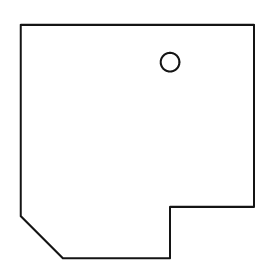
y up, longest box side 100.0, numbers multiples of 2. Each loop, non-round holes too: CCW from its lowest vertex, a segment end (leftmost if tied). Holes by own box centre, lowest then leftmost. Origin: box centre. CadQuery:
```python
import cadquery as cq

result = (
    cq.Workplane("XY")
    .moveTo(-32.0, -50.0)
    .lineTo(14.0, -50.0)
    .lineTo(14.0, -28.0)
    .lineTo(50.0, -28.0)
    .lineTo(50.0, 50.0)
    .lineTo(-50.0, 50.0)
    .lineTo(-50.0, -32.0)
    .close()
    .moveTo(14.0, 34.0)
    .circle(4.0)
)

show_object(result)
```